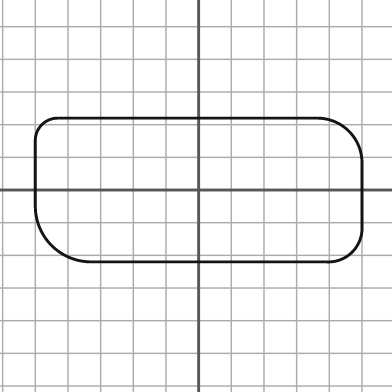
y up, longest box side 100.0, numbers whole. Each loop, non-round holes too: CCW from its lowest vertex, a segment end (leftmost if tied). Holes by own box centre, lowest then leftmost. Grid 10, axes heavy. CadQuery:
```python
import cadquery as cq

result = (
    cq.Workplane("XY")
    .moveTo(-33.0, -22.0)
    .lineTo(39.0, -22.0)
    .threePointArc((47.0, -19.0), (50.0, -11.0))
    .lineTo(50.0, 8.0)
    .threePointArc((46.0, 18.0), (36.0, 22.0))
    .lineTo(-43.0, 22.0)
    .threePointArc((-48.0, 20.0), (-50.0, 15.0))
    .lineTo(-50.0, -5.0)
    .threePointArc((-45.0, -17.0), (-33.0, -22.0))
    .close()
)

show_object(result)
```